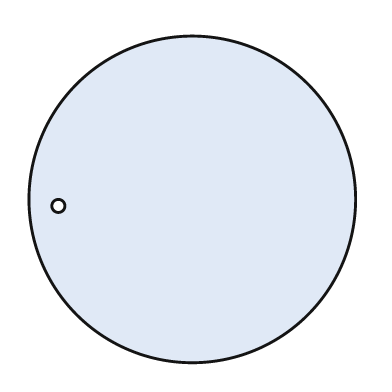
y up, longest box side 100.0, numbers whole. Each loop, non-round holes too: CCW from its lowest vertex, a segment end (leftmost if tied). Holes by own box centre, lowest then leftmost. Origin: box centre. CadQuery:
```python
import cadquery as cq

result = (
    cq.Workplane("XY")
    .moveTo(0.0, 0.0)
    .circle(50.0)
    .moveTo(-41.0, -2.0)
    .circle(2.0)
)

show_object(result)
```